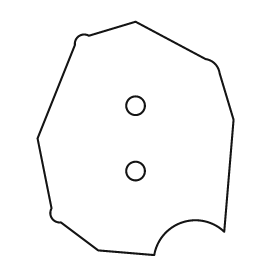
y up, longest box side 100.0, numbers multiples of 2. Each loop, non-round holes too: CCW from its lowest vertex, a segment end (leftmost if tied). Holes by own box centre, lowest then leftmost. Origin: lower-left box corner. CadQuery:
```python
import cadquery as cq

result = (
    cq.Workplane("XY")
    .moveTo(50.0, 0.0)
    .threePointArc((62.0, 14.0), (80.0, 10.0))
    .lineTo(84.0, 58.0)
    .lineTo(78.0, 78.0)
    .threePointArc((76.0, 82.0), (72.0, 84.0))
    .lineTo(42.0, 100.0)
    .lineTo(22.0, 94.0)
    .threePointArc((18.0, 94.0), (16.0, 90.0))
    .lineTo(0.0, 50.0)
    .lineTo(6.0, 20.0)
    .threePointArc((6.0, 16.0), (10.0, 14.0))
    .lineTo(26.0, 2.0)
    .close()
    .moveTo(42.0, 36.0)
    .circle(4.0)
    .moveTo(42.0, 64.0)
    .circle(4.0)
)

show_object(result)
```